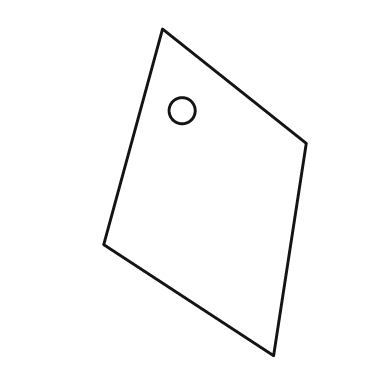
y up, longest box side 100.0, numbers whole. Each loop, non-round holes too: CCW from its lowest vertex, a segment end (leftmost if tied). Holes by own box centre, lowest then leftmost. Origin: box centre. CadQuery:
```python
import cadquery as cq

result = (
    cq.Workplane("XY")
    .moveTo(21.0, -50.0)
    .lineTo(31.0, 15.0)
    .lineTo(-13.0, 50.0)
    .lineTo(-31.0, -16.0)
    .close()
    .moveTo(-7.0, 25.0)
    .circle(4.0)
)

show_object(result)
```